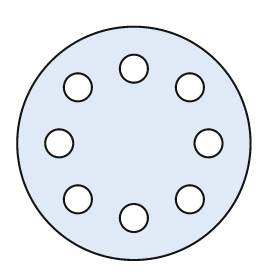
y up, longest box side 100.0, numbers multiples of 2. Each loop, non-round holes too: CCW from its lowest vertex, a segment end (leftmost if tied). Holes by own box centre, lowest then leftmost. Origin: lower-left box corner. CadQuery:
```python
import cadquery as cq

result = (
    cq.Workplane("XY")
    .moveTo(50.0, 50.0)
    .circle(50.0)
    .moveTo(50.0, 18.0)
    .circle(6.0)
    .moveTo(26.0, 26.0)
    .circle(6.0)
    .moveTo(74.0, 26.0)
    .circle(6.0)
    .moveTo(18.0, 50.0)
    .circle(6.0)
    .moveTo(82.0, 50.0)
    .circle(6.0)
    .moveTo(26.0, 74.0)
    .circle(6.0)
    .moveTo(74.0, 74.0)
    .circle(6.0)
    .moveTo(50.0, 82.0)
    .circle(6.0)
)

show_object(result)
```